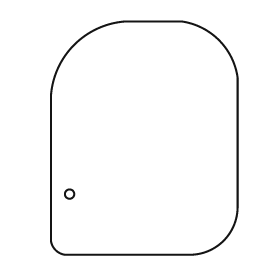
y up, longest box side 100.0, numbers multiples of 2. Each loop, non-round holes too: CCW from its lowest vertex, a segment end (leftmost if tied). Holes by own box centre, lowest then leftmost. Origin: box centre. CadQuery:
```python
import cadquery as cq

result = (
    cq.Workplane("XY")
    .moveTo(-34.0, -50.0)
    .lineTo(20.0, -50.0)
    .threePointArc((34.0, -44.0), (40.0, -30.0))
    .lineTo(40.0, 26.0)
    .threePointArc((32.0, 42.0), (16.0, 50.0))
    .lineTo(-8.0, 50.0)
    .threePointArc((-30.0, 40.0), (-40.0, 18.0))
    .lineTo(-40.0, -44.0)
    .threePointArc((-38.0, -48.0), (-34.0, -50.0))
    .close()
    .moveTo(-32.0, -24.0)
    .circle(2.0)
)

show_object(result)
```